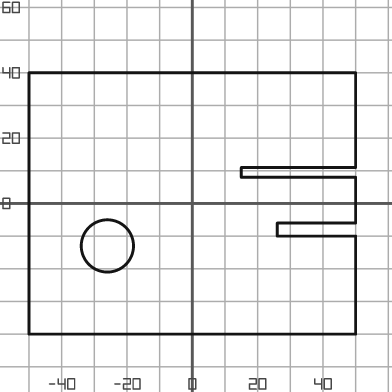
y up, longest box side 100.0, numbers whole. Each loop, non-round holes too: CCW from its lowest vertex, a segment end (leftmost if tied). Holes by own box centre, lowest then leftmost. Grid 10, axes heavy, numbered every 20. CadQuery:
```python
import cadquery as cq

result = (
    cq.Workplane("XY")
    .moveTo(-50.0, -40.0)
    .lineTo(50.0, -40.0)
    .lineTo(50.0, -10.0)
    .lineTo(26.0, -10.0)
    .lineTo(26.0, -6.0)
    .lineTo(50.0, -6.0)
    .lineTo(50.0, 8.0)
    .lineTo(15.0, 8.0)
    .lineTo(15.0, 11.0)
    .lineTo(50.0, 11.0)
    .lineTo(50.0, 40.0)
    .lineTo(-50.0, 40.0)
    .close()
    .moveTo(-26.0, -13.0)
    .circle(8.0)
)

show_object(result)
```